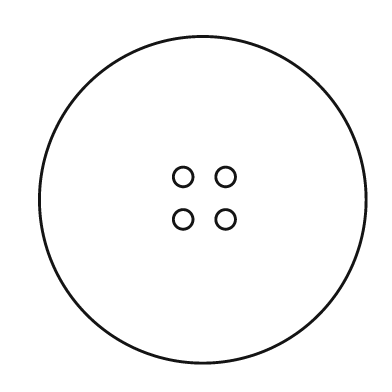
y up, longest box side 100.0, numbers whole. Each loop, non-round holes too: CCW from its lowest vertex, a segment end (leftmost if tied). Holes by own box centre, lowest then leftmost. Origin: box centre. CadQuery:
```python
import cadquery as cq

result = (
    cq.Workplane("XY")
    .moveTo(0.0, 0.0)
    .circle(50.0)
    .moveTo(-6.0, -6.0)
    .circle(3.0)
    .moveTo(7.0, -6.0)
    .circle(3.0)
    .moveTo(-6.0, 7.0)
    .circle(3.0)
    .moveTo(7.0, 7.0)
    .circle(3.0)
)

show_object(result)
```